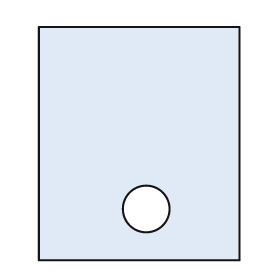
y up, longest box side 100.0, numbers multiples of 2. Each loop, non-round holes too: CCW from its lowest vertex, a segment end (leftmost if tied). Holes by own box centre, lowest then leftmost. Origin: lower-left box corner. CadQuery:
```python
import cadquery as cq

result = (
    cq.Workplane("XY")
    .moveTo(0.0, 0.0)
    .lineTo(86.0, 0.0)
    .lineTo(86.0, 100.0)
    .lineTo(0.0, 100.0)
    .close()
    .moveTo(46.0, 22.0)
    .circle(10.0)
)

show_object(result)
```